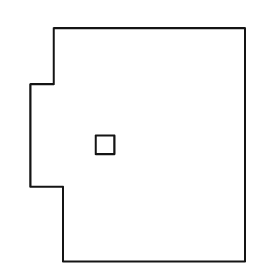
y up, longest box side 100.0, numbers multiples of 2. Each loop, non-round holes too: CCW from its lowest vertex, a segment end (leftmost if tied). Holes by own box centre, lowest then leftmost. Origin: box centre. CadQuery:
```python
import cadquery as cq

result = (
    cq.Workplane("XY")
    .moveTo(-32.0, -50.0)
    .lineTo(46.0, -50.0)
    .lineTo(46.0, 50.0)
    .lineTo(-36.0, 50.0)
    .lineTo(-36.0, 26.0)
    .lineTo(-46.0, 26.0)
    .lineTo(-46.0, -18.0)
    .lineTo(-32.0, -18.0)
    .close()
    .moveTo(-18.0, -4.0)
    .lineTo(-10.0, -4.0)
    .lineTo(-10.0, 4.0)
    .lineTo(-18.0, 4.0)
    .close()
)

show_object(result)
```